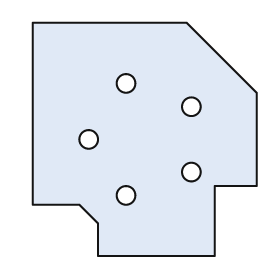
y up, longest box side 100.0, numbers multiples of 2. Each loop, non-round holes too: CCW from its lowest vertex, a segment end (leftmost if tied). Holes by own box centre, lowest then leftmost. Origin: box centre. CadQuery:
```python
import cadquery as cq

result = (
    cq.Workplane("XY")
    .moveTo(-20.0, -50.0)
    .lineTo(30.0, -50.0)
    .lineTo(30.0, -20.0)
    .lineTo(48.0, -20.0)
    .lineTo(48.0, 20.0)
    .lineTo(18.0, 50.0)
    .lineTo(-48.0, 50.0)
    .lineTo(-48.0, -28.0)
    .lineTo(-28.0, -28.0)
    .lineTo(-20.0, -36.0)
    .close()
    .moveTo(-8.0, -24.0)
    .circle(4.0)
    .moveTo(20.0, -14.0)
    .circle(4.0)
    .moveTo(-24.0, 0.0)
    .circle(4.0)
    .moveTo(20.0, 14.0)
    .circle(4.0)
    .moveTo(-8.0, 24.0)
    .circle(4.0)
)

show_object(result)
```